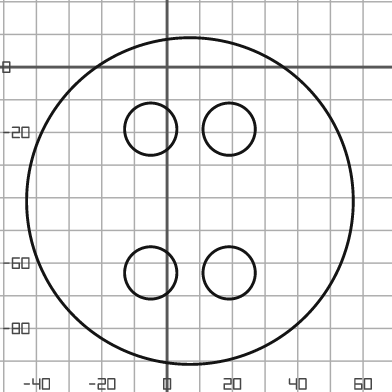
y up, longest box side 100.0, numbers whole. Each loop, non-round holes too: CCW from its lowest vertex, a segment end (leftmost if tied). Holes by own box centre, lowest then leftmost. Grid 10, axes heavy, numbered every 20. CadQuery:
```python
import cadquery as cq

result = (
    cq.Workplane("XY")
    .moveTo(7.0, -41.0)
    .circle(50.0)
    .moveTo(-5.0, -63.0)
    .circle(8.0)
    .moveTo(19.0, -63.0)
    .circle(8.0)
    .moveTo(-5.0, -19.0)
    .circle(8.0)
    .moveTo(19.0, -19.0)
    .circle(8.0)
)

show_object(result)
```